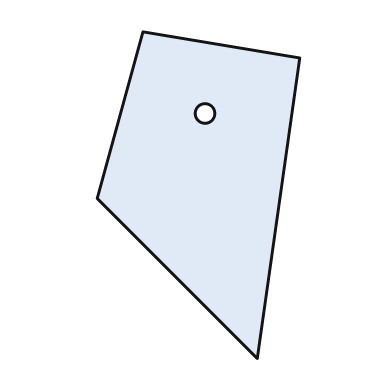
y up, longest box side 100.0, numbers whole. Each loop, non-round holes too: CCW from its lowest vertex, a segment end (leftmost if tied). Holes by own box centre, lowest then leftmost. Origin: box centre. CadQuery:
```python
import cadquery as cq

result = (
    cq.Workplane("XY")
    .moveTo(18.0, -50.0)
    .lineTo(31.0, 42.0)
    .lineTo(-17.0, 50.0)
    .lineTo(-31.0, -1.0)
    .close()
    .moveTo(2.0, 25.0)
    .circle(3.0)
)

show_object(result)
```